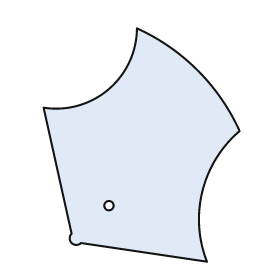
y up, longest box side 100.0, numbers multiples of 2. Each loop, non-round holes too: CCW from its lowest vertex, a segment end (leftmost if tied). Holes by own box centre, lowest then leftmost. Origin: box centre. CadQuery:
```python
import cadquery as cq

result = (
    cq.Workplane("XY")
    .moveTo(28.0, -50.0)
    .threePointArc((26.0, -20.0), (42.0, 6.0))
    .threePointArc((24.0, 32.0), (-2.0, 50.0))
    .threePointArc((-14.0, 24.0), (-42.0, 16.0))
    .lineTo(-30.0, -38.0)
    .threePointArc((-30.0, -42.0), (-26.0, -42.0))
    .close()
    .moveTo(-14.0, -26.0)
    .circle(2.0)
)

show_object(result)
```